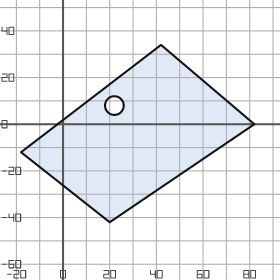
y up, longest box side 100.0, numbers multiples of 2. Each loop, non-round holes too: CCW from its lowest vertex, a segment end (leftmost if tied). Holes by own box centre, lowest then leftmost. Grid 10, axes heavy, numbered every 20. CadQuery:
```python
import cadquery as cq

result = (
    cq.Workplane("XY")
    .moveTo(20.0, -42.0)
    .lineTo(82.0, 0.0)
    .lineTo(42.0, 34.0)
    .lineTo(-18.0, -12.0)
    .close()
    .moveTo(22.0, 8.0)
    .circle(4.0)
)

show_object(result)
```